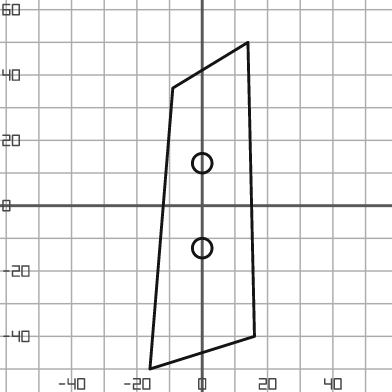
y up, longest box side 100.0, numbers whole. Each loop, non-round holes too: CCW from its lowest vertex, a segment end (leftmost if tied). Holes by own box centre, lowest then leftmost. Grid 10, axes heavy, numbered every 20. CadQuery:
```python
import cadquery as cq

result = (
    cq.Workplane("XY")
    .moveTo(-16.0, -50.0)
    .lineTo(16.0, -40.0)
    .lineTo(14.0, 50.0)
    .lineTo(-9.0, 36.0)
    .close()
    .moveTo(0.0, -13.0)
    .circle(3.0)
    .moveTo(0.0, 13.0)
    .circle(3.0)
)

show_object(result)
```